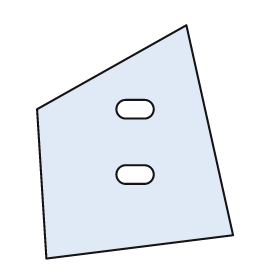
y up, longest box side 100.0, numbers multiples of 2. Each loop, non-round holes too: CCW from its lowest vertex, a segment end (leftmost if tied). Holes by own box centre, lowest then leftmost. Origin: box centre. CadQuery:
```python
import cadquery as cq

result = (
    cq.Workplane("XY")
    .moveTo(-38.0, -50.0)
    .lineTo(42.0, -40.0)
    .lineTo(22.0, 50.0)
    .lineTo(-42.0, 14.0)
    .close()
    .moveTo(-4.0, -18.0)
    .lineTo(4.0, -18.0)
    .threePointArc((8.0, -14.0), (4.0, -10.0))
    .lineTo(-4.0, -10.0)
    .threePointArc((-8.0, -14.0), (-4.0, -18.0))
    .close()
    .moveTo(-4.0, 10.0)
    .lineTo(4.0, 10.0)
    .threePointArc((8.0, 14.0), (4.0, 18.0))
    .lineTo(-4.0, 18.0)
    .threePointArc((-8.0, 14.0), (-4.0, 10.0))
    .close()
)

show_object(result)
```